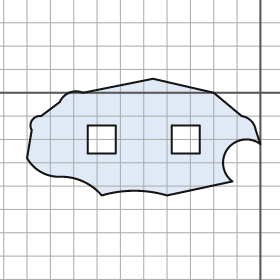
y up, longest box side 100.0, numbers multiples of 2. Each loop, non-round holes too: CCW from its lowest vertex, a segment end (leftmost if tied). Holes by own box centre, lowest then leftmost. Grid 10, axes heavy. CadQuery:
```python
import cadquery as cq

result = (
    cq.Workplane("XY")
    .moveTo(-68.0, -44.0)
    .threePointArc((-54.0, -42.0), (-40.0, -44.0))
    .lineTo(-12.0, -38.0)
    .threePointArc((-14.0, -24.0), (0.0, -22.0))
    .lineTo(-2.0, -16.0)
    .threePointArc((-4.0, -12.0), (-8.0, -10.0))
    .lineTo(-20.0, 0.0)
    .lineTo(-46.0, 6.0)
    .lineTo(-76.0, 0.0)
    .threePointArc((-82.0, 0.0), (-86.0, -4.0))
    .lineTo(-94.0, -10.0)
    .threePointArc((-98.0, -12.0), (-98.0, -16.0))
    .lineTo(-100.0, -28.0)
    .threePointArc((-94.0, -34.0), (-86.0, -36.0))
    .threePointArc((-76.0, -38.0), (-68.0, -44.0))
    .close()
    .moveTo(-74.0, -26.0)
    .lineTo(-62.0, -26.0)
    .lineTo(-62.0, -14.0)
    .lineTo(-74.0, -14.0)
    .close()
    .moveTo(-38.0, -26.0)
    .lineTo(-26.0, -26.0)
    .lineTo(-26.0, -14.0)
    .lineTo(-38.0, -14.0)
    .close()
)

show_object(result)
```